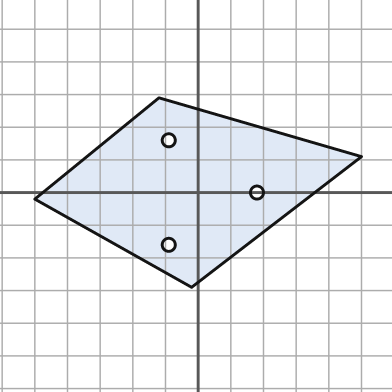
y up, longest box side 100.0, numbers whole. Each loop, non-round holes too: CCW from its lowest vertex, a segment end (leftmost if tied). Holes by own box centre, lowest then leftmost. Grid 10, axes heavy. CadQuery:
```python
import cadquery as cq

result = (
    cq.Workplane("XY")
    .moveTo(-2.0, -29.0)
    .lineTo(50.0, 11.0)
    .lineTo(-12.0, 29.0)
    .lineTo(-50.0, -2.0)
    .close()
    .moveTo(-9.0, -16.0)
    .circle(2.0)
    .moveTo(18.0, 0.0)
    .circle(2.0)
    .moveTo(-9.0, 16.0)
    .circle(2.0)
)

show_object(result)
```